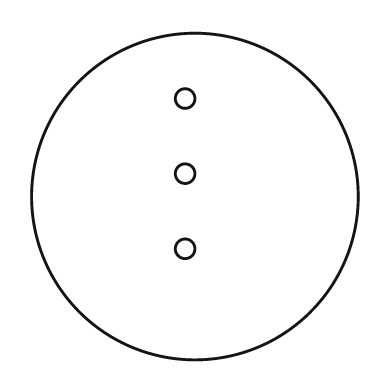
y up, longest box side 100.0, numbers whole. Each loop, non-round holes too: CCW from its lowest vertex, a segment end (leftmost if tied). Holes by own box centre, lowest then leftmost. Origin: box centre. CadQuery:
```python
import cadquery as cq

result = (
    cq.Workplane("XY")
    .moveTo(0.0, 0.0)
    .circle(50.0)
    .moveTo(-3.0, -16.0)
    .circle(3.0)
    .moveTo(-3.0, 7.0)
    .circle(3.0)
    .moveTo(-3.0, 30.0)
    .circle(3.0)
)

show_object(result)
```